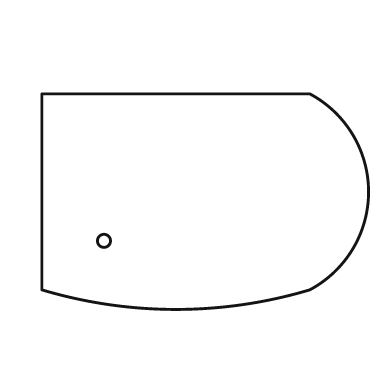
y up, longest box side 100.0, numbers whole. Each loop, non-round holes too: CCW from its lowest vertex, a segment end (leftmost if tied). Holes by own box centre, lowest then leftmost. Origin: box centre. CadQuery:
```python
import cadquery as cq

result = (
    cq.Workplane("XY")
    .moveTo(-50.0, -27.0)
    .threePointArc((-9.0, -33.0), (32.0, -27.0))
    .threePointArc((50.0, 3.0), (32.0, 33.0))
    .lineTo(-50.0, 33.0)
    .close()
    .moveTo(-31.0, -12.0)
    .circle(2.0)
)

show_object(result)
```